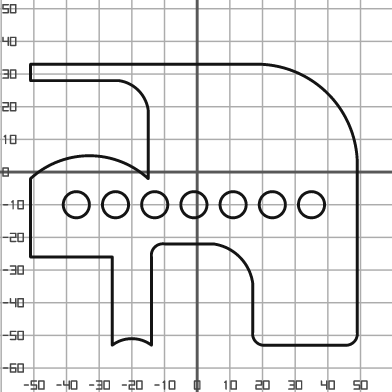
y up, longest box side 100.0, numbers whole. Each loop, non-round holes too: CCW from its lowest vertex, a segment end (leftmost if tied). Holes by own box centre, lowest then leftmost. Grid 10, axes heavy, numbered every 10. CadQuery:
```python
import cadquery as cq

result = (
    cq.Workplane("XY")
    .moveTo(-26.0, -53.0)
    .threePointArc((-20.0, -51.0), (-14.0, -53.0))
    .lineTo(-14.0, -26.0)
    .threePointArc((-13.0, -23.0), (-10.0, -22.0))
    .lineTo(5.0, -22.0)
    .threePointArc((13.0, -26.0), (17.0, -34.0))
    .lineTo(17.0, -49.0)
    .threePointArc((18.0, -52.0), (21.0, -53.0))
    .lineTo(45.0, -53.0)
    .threePointArc((48.0, -52.0), (49.0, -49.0))
    .lineTo(49.0, 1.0)
    .threePointArc((40.0, 24.0), (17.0, 33.0))
    .lineTo(-51.0, 33.0)
    .lineTo(-51.0, 28.0)
    .lineTo(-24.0, 28.0)
    .threePointArc((-18.0, 25.0), (-15.0, 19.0))
    .lineTo(-15.0, -2.0)
    .threePointArc((-33.0, 5.0), (-51.0, -2.0))
    .lineTo(-51.0, -26.0)
    .lineTo(-26.0, -26.0)
    .close()
    .moveTo(-37.0, -10.0)
    .circle(4.0)
    .moveTo(-25.0, -10.0)
    .circle(4.0)
    .moveTo(-13.0, -10.0)
    .circle(4.0)
    .moveTo(-1.0, -10.0)
    .circle(4.0)
    .moveTo(11.0, -10.0)
    .circle(4.0)
    .moveTo(23.0, -10.0)
    .circle(4.0)
    .moveTo(35.0, -10.0)
    .circle(4.0)
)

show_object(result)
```